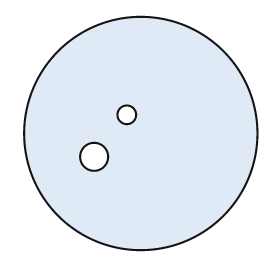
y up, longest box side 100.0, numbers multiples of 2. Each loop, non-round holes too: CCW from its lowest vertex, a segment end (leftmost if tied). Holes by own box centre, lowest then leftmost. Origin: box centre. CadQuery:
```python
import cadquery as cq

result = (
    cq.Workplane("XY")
    .moveTo(0.0, 0.0)
    .circle(50.0)
    .moveTo(-20.0, -10.0)
    .circle(6.0)
    .moveTo(-6.0, 8.0)
    .circle(4.0)
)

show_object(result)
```